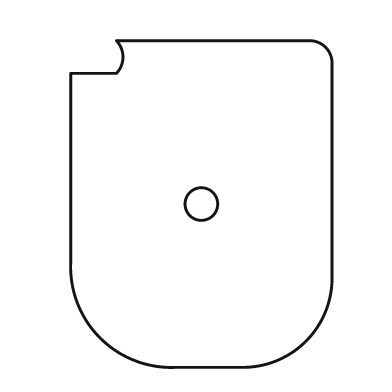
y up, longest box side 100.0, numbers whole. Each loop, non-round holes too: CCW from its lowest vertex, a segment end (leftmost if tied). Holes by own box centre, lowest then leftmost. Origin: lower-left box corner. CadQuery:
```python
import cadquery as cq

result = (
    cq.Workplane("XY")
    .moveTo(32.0, 0.0)
    .lineTo(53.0, 0.0)
    .threePointArc((72.0, 8.0), (80.0, 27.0))
    .lineTo(80.0, 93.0)
    .threePointArc((78.0, 98.0), (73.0, 100.0))
    .lineTo(14.0, 100.0)
    .threePointArc((16.0, 95.0), (14.0, 90.0))
    .lineTo(0.0, 90.0)
    .lineTo(0.0, 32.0)
    .threePointArc((9.0, 9.0), (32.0, 0.0))
    .close()
    .moveTo(40.0, 50.0)
    .circle(5.0)
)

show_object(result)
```